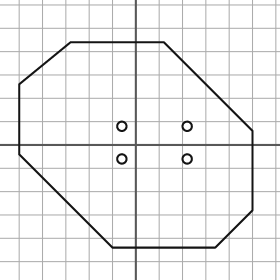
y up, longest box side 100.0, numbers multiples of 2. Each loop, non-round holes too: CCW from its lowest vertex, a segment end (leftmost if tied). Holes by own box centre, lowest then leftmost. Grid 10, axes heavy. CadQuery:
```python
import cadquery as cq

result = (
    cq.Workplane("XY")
    .moveTo(-10.0, -44.0)
    .lineTo(34.0, -44.0)
    .lineTo(50.0, -28.0)
    .lineTo(50.0, 6.0)
    .lineTo(12.0, 44.0)
    .lineTo(-28.0, 44.0)
    .lineTo(-50.0, 26.0)
    .lineTo(-50.0, -4.0)
    .close()
    .moveTo(-6.0, -6.0)
    .circle(2.0)
    .moveTo(22.0, -6.0)
    .circle(2.0)
    .moveTo(-6.0, 8.0)
    .circle(2.0)
    .moveTo(22.0, 8.0)
    .circle(2.0)
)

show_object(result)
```